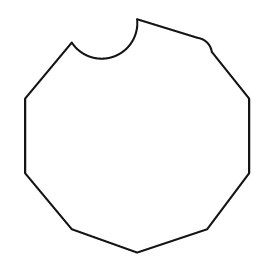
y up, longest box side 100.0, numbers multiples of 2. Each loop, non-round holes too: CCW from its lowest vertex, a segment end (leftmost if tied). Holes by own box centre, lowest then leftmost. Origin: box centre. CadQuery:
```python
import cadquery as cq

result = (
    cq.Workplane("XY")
    .moveTo(0.0, -50.0)
    .lineTo(30.0, -40.0)
    .lineTo(48.0, -16.0)
    .lineTo(48.0, 16.0)
    .lineTo(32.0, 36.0)
    .threePointArc((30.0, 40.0), (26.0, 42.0))
    .lineTo(0.0, 50.0)
    .threePointArc((-10.0, 34.0), (-28.0, 40.0))
    .lineTo(-48.0, 16.0)
    .lineTo(-48.0, -16.0)
    .lineTo(-28.0, -40.0)
    .close()
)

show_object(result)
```